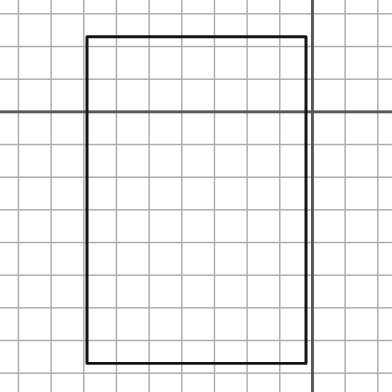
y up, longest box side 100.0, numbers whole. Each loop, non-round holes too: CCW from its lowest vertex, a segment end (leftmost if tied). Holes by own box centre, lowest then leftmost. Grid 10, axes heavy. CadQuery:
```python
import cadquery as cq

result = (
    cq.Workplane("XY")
    .moveTo(-69.0, -77.0)
    .lineTo(-2.0, -77.0)
    .lineTo(-2.0, 23.0)
    .lineTo(-69.0, 23.0)
    .close()
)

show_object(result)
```